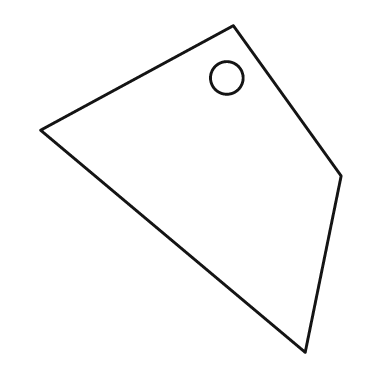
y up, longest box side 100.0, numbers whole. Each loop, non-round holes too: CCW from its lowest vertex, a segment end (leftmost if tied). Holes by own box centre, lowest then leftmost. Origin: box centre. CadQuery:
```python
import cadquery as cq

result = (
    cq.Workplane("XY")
    .moveTo(35.0, -50.0)
    .lineTo(46.0, 4.0)
    .lineTo(13.0, 50.0)
    .lineTo(-46.0, 18.0)
    .close()
    .moveTo(11.0, 34.0)
    .circle(5.0)
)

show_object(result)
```